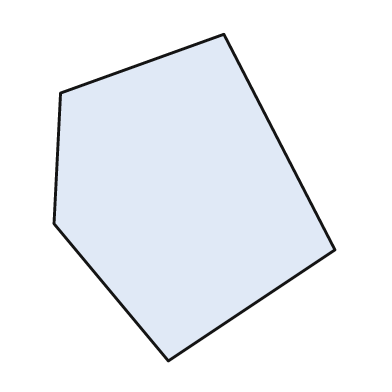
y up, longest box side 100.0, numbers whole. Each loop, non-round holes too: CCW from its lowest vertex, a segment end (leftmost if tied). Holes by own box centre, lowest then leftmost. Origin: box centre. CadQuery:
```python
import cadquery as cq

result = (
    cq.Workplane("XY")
    .moveTo(-8.0, -50.0)
    .lineTo(43.0, -16.0)
    .lineTo(9.0, 50.0)
    .lineTo(-41.0, 32.0)
    .lineTo(-43.0, -8.0)
    .close()
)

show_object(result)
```